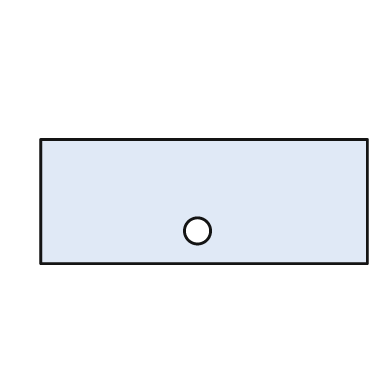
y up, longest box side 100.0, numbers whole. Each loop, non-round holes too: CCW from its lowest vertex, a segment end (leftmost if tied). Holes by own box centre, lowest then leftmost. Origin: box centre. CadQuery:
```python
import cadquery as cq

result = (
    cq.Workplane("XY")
    .moveTo(-50.0, -19.0)
    .lineTo(50.0, -19.0)
    .lineTo(50.0, 19.0)
    .lineTo(-50.0, 19.0)
    .close()
    .moveTo(-2.0, -9.0)
    .circle(4.0)
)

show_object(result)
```